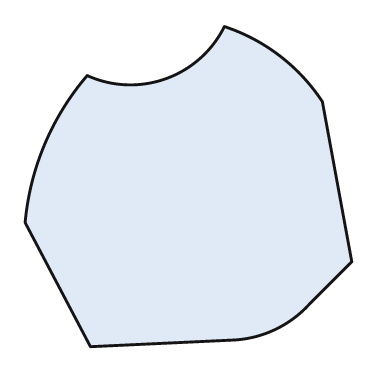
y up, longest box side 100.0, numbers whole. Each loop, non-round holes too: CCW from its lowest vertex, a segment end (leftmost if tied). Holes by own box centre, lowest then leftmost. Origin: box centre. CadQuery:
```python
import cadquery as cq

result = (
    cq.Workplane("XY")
    .moveTo(-30.0, -49.0)
    .lineTo(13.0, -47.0)
    .threePointArc((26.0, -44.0), (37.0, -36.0))
    .lineTo(50.0, -23.0)
    .lineTo(41.0, 26.0)
    .threePointArc((28.0, 40.0), (11.0, 49.0))
    .threePointArc((-7.0, 33.0), (-31.0, 34.0))
    .threePointArc((-44.0, 13.0), (-50.0, -11.0))
    .close()
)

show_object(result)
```